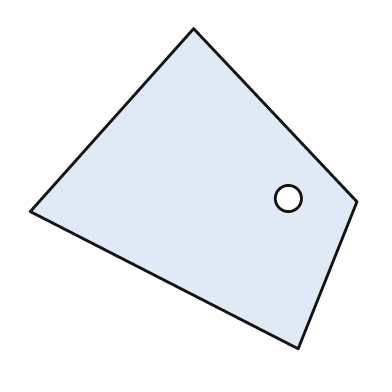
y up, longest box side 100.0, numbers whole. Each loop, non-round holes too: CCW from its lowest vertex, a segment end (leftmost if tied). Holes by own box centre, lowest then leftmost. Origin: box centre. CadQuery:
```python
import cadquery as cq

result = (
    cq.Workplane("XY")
    .moveTo(32.0, -49.0)
    .lineTo(50.0, -4.0)
    .lineTo(0.0, 49.0)
    .lineTo(-50.0, -7.0)
    .close()
    .moveTo(29.0, -3.0)
    .circle(4.0)
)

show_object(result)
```